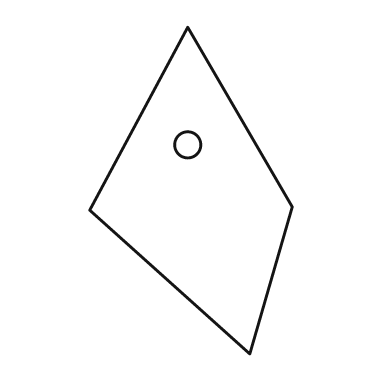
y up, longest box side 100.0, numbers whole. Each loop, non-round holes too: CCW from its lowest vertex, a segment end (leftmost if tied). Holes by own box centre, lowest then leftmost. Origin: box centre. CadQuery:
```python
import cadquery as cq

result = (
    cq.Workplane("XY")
    .moveTo(18.0, -50.0)
    .lineTo(31.0, -5.0)
    .lineTo(-1.0, 50.0)
    .lineTo(-31.0, -6.0)
    .close()
    .moveTo(-1.0, 14.0)
    .circle(4.0)
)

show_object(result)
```